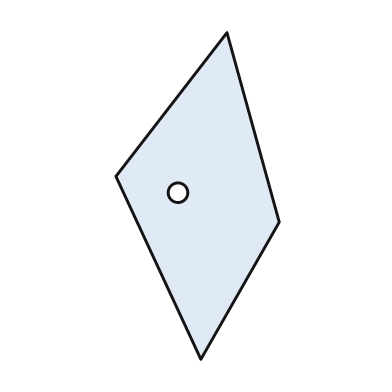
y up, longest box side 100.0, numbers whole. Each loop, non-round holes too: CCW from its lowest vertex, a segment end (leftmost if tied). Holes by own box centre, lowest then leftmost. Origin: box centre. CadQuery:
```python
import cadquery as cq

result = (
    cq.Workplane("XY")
    .moveTo(1.0, -50.0)
    .lineTo(25.0, -8.0)
    .lineTo(9.0, 50.0)
    .lineTo(-25.0, 6.0)
    .close()
    .moveTo(-6.0, 1.0)
    .circle(3.0)
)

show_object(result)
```